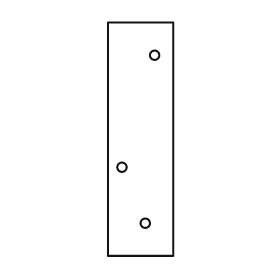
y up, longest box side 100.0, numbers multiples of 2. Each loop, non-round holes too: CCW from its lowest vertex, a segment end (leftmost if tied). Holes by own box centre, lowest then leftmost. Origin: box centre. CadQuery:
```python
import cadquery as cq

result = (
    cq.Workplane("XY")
    .moveTo(-14.0, -50.0)
    .lineTo(14.0, -50.0)
    .lineTo(14.0, 50.0)
    .lineTo(-14.0, 50.0)
    .close()
    .moveTo(2.0, -36.0)
    .circle(2.0)
    .moveTo(-8.0, -12.0)
    .circle(2.0)
    .moveTo(6.0, 36.0)
    .circle(2.0)
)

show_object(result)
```